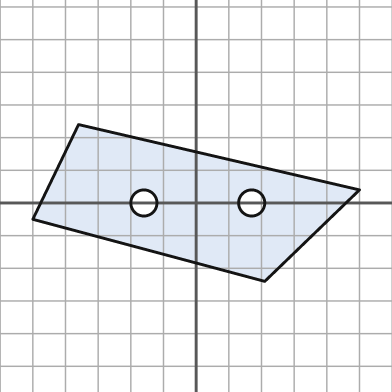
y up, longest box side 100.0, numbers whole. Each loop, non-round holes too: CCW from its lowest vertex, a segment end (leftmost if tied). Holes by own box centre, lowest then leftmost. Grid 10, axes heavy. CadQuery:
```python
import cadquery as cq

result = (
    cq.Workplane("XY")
    .moveTo(21.0, -24.0)
    .lineTo(50.0, 4.0)
    .lineTo(-36.0, 24.0)
    .lineTo(-50.0, -5.0)
    .close()
    .moveTo(-16.0, 0.0)
    .circle(4.0)
    .moveTo(17.0, 0.0)
    .circle(4.0)
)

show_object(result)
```